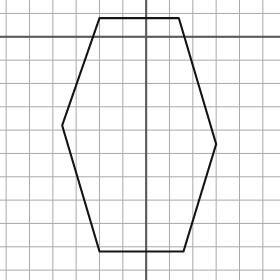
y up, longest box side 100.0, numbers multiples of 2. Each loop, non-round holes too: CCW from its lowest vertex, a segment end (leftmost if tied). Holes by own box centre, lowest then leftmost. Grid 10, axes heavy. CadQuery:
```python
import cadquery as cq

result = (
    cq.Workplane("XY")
    .moveTo(-20.0, -92.0)
    .lineTo(16.0, -92.0)
    .lineTo(30.0, -46.0)
    .lineTo(14.0, 8.0)
    .lineTo(-20.0, 8.0)
    .lineTo(-36.0, -38.0)
    .close()
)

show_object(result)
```